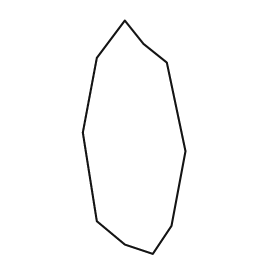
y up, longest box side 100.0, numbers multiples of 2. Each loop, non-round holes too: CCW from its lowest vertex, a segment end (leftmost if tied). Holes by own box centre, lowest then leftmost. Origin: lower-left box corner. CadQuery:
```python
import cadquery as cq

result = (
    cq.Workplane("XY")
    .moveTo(30.0, 0.0)
    .lineTo(38.0, 12.0)
    .lineTo(44.0, 44.0)
    .lineTo(36.0, 82.0)
    .lineTo(26.0, 90.0)
    .lineTo(18.0, 100.0)
    .lineTo(6.0, 84.0)
    .lineTo(0.0, 52.0)
    .lineTo(6.0, 14.0)
    .lineTo(18.0, 4.0)
    .close()
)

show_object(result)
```